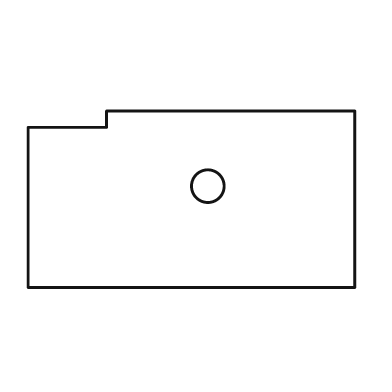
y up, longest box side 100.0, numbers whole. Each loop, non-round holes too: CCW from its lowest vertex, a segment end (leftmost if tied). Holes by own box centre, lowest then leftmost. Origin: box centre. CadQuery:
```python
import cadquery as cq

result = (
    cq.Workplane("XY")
    .moveTo(-50.0, -27.0)
    .lineTo(50.0, -27.0)
    .lineTo(50.0, 27.0)
    .lineTo(-26.0, 27.0)
    .lineTo(-26.0, 22.0)
    .lineTo(-50.0, 22.0)
    .close()
    .moveTo(5.0, 4.0)
    .circle(5.0)
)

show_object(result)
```